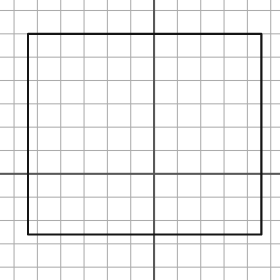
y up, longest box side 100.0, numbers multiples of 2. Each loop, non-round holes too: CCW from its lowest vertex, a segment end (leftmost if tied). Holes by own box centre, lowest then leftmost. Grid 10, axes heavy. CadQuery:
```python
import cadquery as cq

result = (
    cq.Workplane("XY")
    .moveTo(-54.0, -26.0)
    .lineTo(46.0, -26.0)
    .lineTo(46.0, 60.0)
    .lineTo(-54.0, 60.0)
    .close()
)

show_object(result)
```